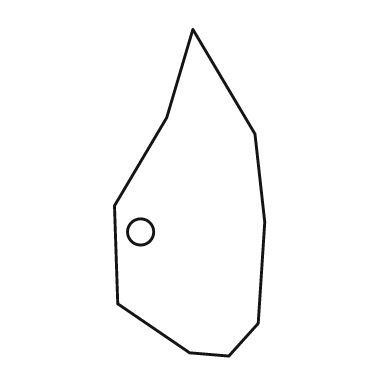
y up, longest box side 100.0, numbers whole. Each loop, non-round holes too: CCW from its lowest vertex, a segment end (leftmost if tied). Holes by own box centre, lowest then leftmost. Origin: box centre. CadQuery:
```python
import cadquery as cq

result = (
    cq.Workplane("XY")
    .moveTo(12.0, -50.0)
    .lineTo(21.0, -40.0)
    .lineTo(23.0, -9.0)
    .lineTo(20.0, 18.0)
    .lineTo(1.0, 50.0)
    .lineTo(-7.0, 23.0)
    .lineTo(-23.0, -4.0)
    .lineTo(-22.0, -34.0)
    .lineTo(0.0, -49.0)
    .close()
    .moveTo(-15.0, -12.0)
    .circle(4.0)
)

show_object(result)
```